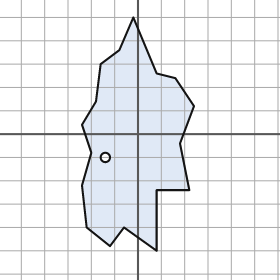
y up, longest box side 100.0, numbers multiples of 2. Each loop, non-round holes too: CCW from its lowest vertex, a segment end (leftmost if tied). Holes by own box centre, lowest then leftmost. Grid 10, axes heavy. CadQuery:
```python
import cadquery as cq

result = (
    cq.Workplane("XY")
    .moveTo(8.0, -50.0)
    .lineTo(8.0, -24.0)
    .lineTo(22.0, -24.0)
    .lineTo(18.0, -4.0)
    .lineTo(24.0, 12.0)
    .lineTo(16.0, 24.0)
    .lineTo(8.0, 26.0)
    .lineTo(-2.0, 50.0)
    .lineTo(-8.0, 36.0)
    .lineTo(-16.0, 30.0)
    .lineTo(-18.0, 14.0)
    .lineTo(-24.0, 4.0)
    .lineTo(-20.0, -8.0)
    .lineTo(-24.0, -22.0)
    .lineTo(-22.0, -40.0)
    .lineTo(-12.0, -48.0)
    .lineTo(-6.0, -40.0)
    .close()
    .moveTo(-14.0, -10.0)
    .circle(2.0)
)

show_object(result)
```